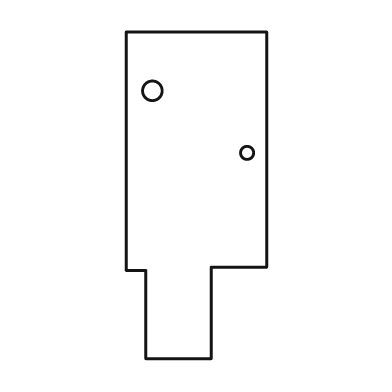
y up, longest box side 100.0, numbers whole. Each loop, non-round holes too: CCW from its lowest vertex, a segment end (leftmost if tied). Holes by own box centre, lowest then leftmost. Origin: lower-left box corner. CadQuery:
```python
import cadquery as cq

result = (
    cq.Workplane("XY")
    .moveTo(6.0, 0.0)
    .lineTo(26.0, 0.0)
    .lineTo(26.0, 28.0)
    .lineTo(43.0, 28.0)
    .lineTo(43.0, 100.0)
    .lineTo(0.0, 100.0)
    .lineTo(0.0, 27.0)
    .lineTo(6.0, 27.0)
    .close()
    .moveTo(37.0, 63.0)
    .circle(2.0)
    .moveTo(8.0, 82.0)
    .circle(3.0)
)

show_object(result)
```